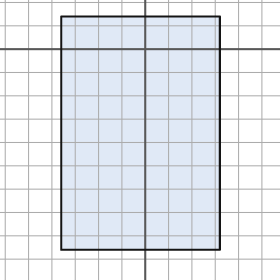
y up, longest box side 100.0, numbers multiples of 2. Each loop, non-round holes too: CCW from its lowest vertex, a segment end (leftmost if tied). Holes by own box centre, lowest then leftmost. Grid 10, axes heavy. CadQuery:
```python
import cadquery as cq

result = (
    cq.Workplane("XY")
    .moveTo(-36.0, -86.0)
    .lineTo(32.0, -86.0)
    .lineTo(32.0, 14.0)
    .lineTo(-36.0, 14.0)
    .close()
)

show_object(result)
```